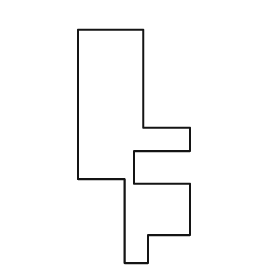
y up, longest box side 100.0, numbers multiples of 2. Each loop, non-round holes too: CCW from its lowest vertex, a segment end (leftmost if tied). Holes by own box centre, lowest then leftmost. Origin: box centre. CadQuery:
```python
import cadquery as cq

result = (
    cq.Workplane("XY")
    .moveTo(-4.0, -50.0)
    .lineTo(6.0, -50.0)
    .lineTo(6.0, -38.0)
    .lineTo(24.0, -38.0)
    .lineTo(24.0, -16.0)
    .lineTo(0.0, -16.0)
    .lineTo(0.0, -2.0)
    .lineTo(24.0, -2.0)
    .lineTo(24.0, 8.0)
    .lineTo(4.0, 8.0)
    .lineTo(4.0, 50.0)
    .lineTo(-24.0, 50.0)
    .lineTo(-24.0, -14.0)
    .lineTo(-4.0, -14.0)
    .close()
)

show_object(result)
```